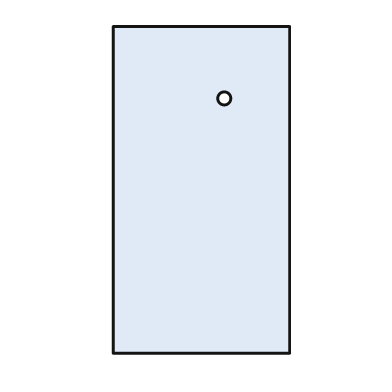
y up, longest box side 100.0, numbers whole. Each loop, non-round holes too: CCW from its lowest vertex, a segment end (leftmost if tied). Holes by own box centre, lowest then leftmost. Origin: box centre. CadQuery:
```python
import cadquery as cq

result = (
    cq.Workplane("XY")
    .moveTo(-27.0, -50.0)
    .lineTo(27.0, -50.0)
    .lineTo(27.0, 50.0)
    .lineTo(-27.0, 50.0)
    .close()
    .moveTo(7.0, 28.0)
    .circle(2.0)
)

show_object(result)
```